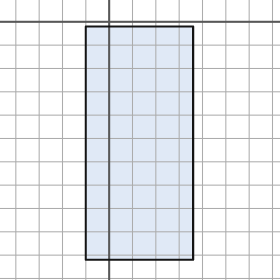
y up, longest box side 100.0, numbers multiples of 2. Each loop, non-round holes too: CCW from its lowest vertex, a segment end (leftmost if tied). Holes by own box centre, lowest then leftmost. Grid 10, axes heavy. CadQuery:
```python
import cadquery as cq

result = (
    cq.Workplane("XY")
    .moveTo(-10.0, -102.0)
    .lineTo(36.0, -102.0)
    .lineTo(36.0, -2.0)
    .lineTo(-10.0, -2.0)
    .close()
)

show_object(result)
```